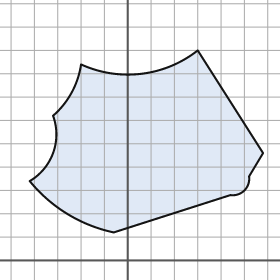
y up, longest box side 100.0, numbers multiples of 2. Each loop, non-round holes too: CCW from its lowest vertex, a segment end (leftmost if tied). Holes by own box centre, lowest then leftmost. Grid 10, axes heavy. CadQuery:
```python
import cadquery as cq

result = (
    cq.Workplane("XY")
    .moveTo(-6.0, 12.0)
    .lineTo(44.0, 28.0)
    .threePointArc((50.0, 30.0), (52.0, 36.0))
    .lineTo(58.0, 46.0)
    .lineTo(30.0, 90.0)
    .threePointArc((6.0, 80.0), (-20.0, 84.0))
    .threePointArc((-24.0, 72.0), (-32.0, 62.0))
    .threePointArc((-32.0, 46.0), (-42.0, 34.0))
    .threePointArc((-26.0, 20.0), (-6.0, 12.0))
    .close()
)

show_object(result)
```